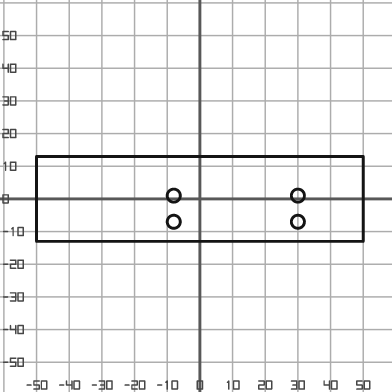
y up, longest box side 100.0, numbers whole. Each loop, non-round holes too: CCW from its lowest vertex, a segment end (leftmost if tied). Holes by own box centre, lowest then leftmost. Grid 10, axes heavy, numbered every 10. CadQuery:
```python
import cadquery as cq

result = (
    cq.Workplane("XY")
    .moveTo(-50.0, -13.0)
    .lineTo(50.0, -13.0)
    .lineTo(50.0, 13.0)
    .lineTo(-50.0, 13.0)
    .close()
    .moveTo(-8.0, -7.0)
    .circle(2.0)
    .moveTo(30.0, -7.0)
    .circle(2.0)
    .moveTo(-8.0, 1.0)
    .circle(2.0)
    .moveTo(30.0, 1.0)
    .circle(2.0)
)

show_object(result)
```